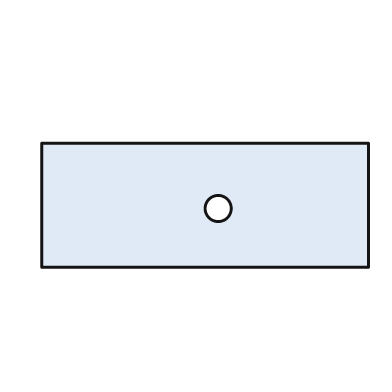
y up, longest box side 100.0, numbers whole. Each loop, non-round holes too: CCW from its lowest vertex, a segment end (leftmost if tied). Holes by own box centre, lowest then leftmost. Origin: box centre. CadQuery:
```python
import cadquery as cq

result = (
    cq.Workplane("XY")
    .moveTo(-50.0, -19.0)
    .lineTo(50.0, -19.0)
    .lineTo(50.0, 19.0)
    .lineTo(-50.0, 19.0)
    .close()
    .moveTo(4.0, -1.0)
    .circle(4.0)
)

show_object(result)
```